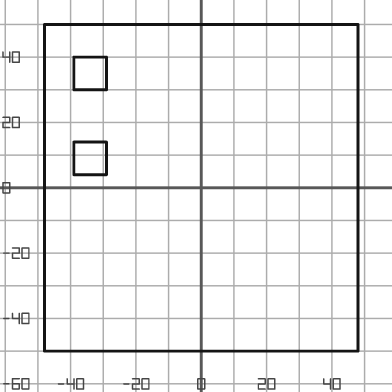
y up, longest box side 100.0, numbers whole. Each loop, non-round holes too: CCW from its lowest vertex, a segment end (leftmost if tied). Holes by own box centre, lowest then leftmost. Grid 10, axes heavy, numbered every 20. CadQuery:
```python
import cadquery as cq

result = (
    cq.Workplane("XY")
    .moveTo(-48.0, -50.0)
    .lineTo(48.0, -50.0)
    .lineTo(48.0, 50.0)
    .lineTo(-48.0, 50.0)
    .close()
    .moveTo(-39.0, 4.0)
    .lineTo(-29.0, 4.0)
    .lineTo(-29.0, 14.0)
    .lineTo(-39.0, 14.0)
    .close()
    .moveTo(-39.0, 30.0)
    .lineTo(-29.0, 30.0)
    .lineTo(-29.0, 40.0)
    .lineTo(-39.0, 40.0)
    .close()
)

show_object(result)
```